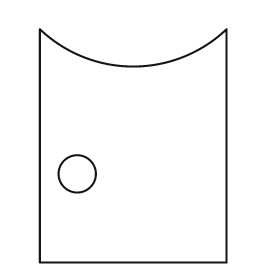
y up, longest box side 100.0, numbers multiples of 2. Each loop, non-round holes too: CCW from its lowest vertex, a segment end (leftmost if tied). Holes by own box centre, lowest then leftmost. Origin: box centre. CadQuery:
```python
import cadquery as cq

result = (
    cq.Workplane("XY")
    .moveTo(-40.0, -50.0)
    .lineTo(40.0, -50.0)
    .lineTo(40.0, 50.0)
    .threePointArc((0.0, 34.0), (-40.0, 50.0))
    .close()
    .moveTo(-24.0, -12.0)
    .circle(8.0)
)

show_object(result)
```